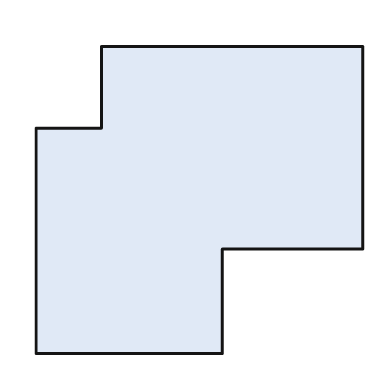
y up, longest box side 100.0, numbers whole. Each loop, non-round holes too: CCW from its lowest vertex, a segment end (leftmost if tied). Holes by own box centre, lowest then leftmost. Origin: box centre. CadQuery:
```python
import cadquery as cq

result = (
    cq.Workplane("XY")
    .moveTo(-50.0, -47.0)
    .lineTo(7.0, -47.0)
    .lineTo(7.0, -15.0)
    .lineTo(50.0, -15.0)
    .lineTo(50.0, 47.0)
    .lineTo(-30.0, 47.0)
    .lineTo(-30.0, 22.0)
    .lineTo(-50.0, 22.0)
    .close()
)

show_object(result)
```